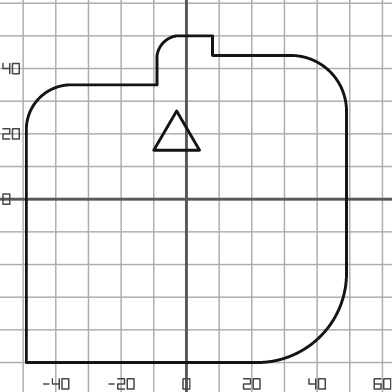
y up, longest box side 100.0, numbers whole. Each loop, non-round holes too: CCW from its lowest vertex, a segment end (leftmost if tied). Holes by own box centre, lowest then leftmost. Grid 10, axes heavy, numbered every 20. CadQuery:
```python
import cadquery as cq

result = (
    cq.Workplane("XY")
    .moveTo(-49.0, -50.0)
    .lineTo(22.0, -50.0)
    .threePointArc((41.0, -42.0), (49.0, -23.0))
    .lineTo(49.0, 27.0)
    .threePointArc((44.0, 39.0), (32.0, 44.0))
    .lineTo(8.0, 44.0)
    .lineTo(8.0, 50.0)
    .lineTo(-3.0, 50.0)
    .threePointArc((-7.0, 48.0), (-9.0, 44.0))
    .lineTo(-9.0, 35.0)
    .lineTo(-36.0, 35.0)
    .threePointArc((-45.0, 31.0), (-49.0, 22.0))
    .close()
    .moveTo(-10.0, 15.0)
    .lineTo(4.0, 15.0)
    .lineTo(-3.0, 27.0)
    .close()
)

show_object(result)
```